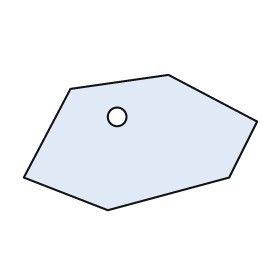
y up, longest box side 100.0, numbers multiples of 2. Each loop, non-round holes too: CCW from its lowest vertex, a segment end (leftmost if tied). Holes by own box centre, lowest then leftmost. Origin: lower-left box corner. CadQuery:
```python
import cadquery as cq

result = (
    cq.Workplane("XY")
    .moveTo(36.0, 0.0)
    .lineTo(88.0, 14.0)
    .lineTo(100.0, 38.0)
    .lineTo(62.0, 58.0)
    .lineTo(20.0, 52.0)
    .lineTo(0.0, 14.0)
    .close()
    .moveTo(40.0, 40.0)
    .circle(4.0)
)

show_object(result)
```